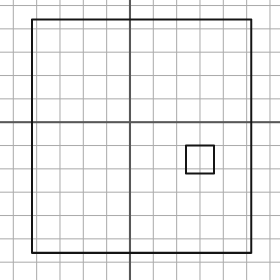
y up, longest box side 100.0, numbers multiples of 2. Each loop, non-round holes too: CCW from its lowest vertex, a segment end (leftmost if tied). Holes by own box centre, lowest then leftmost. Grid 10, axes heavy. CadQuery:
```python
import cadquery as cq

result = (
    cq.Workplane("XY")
    .moveTo(-42.0, -56.0)
    .lineTo(52.0, -56.0)
    .lineTo(52.0, 44.0)
    .lineTo(-42.0, 44.0)
    .close()
    .moveTo(24.0, -22.0)
    .lineTo(36.0, -22.0)
    .lineTo(36.0, -10.0)
    .lineTo(24.0, -10.0)
    .close()
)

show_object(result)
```